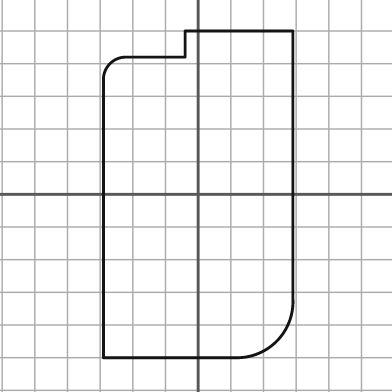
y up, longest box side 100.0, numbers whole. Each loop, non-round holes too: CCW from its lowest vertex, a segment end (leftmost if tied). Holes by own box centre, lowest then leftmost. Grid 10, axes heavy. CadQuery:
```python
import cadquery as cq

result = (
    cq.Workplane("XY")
    .moveTo(-29.0, -50.0)
    .lineTo(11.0, -50.0)
    .threePointArc((24.0, -45.0), (29.0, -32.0))
    .lineTo(29.0, 50.0)
    .lineTo(-4.0, 50.0)
    .lineTo(-4.0, 42.0)
    .lineTo(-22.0, 42.0)
    .threePointArc((-27.0, 40.0), (-29.0, 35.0))
    .close()
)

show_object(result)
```